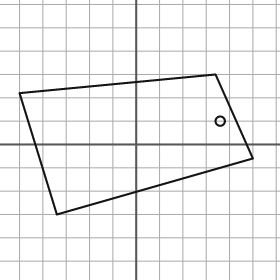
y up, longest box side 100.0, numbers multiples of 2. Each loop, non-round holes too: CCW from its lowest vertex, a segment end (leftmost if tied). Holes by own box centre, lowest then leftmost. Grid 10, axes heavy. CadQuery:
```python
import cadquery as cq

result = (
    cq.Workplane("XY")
    .moveTo(-34.0, -30.0)
    .lineTo(50.0, -6.0)
    .lineTo(34.0, 30.0)
    .lineTo(-50.0, 22.0)
    .close()
    .moveTo(36.0, 10.0)
    .circle(2.0)
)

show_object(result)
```